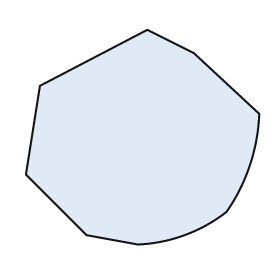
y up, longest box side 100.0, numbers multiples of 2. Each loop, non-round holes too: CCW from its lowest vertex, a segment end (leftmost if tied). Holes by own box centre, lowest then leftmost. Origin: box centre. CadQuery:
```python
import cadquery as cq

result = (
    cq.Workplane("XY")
    .moveTo(-2.0, -46.0)
    .threePointArc((18.0, -42.0), (36.0, -32.0))
    .threePointArc((46.0, -12.0), (50.0, 10.0))
    .lineTo(22.0, 36.0)
    .lineTo(2.0, 46.0)
    .lineTo(-44.0, 22.0)
    .lineTo(-50.0, -16.0)
    .lineTo(-24.0, -42.0)
    .close()
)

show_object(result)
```